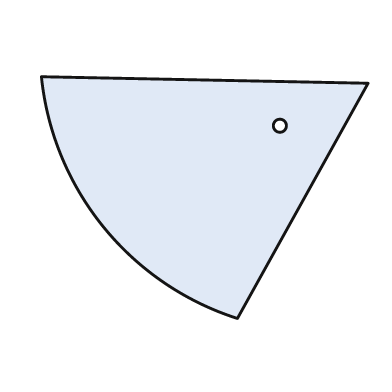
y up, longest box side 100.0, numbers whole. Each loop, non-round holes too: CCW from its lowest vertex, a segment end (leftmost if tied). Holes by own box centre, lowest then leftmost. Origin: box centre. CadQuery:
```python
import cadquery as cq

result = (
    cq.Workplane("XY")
    .moveTo(10.0, -37.0)
    .lineTo(50.0, 35.0)
    .lineTo(-50.0, 37.0)
    .threePointArc((-31.0, -9.0), (10.0, -37.0))
    .close()
    .moveTo(23.0, 22.0)
    .circle(2.0)
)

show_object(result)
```